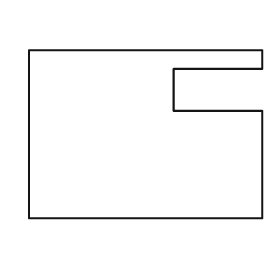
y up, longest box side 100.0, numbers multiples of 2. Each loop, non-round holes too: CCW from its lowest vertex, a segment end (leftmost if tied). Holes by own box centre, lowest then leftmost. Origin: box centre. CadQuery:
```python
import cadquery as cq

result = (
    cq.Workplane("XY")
    .moveTo(-50.0, -36.0)
    .lineTo(50.0, -36.0)
    .lineTo(50.0, 10.0)
    .lineTo(12.0, 10.0)
    .lineTo(12.0, 28.0)
    .lineTo(50.0, 28.0)
    .lineTo(50.0, 36.0)
    .lineTo(-50.0, 36.0)
    .close()
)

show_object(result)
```